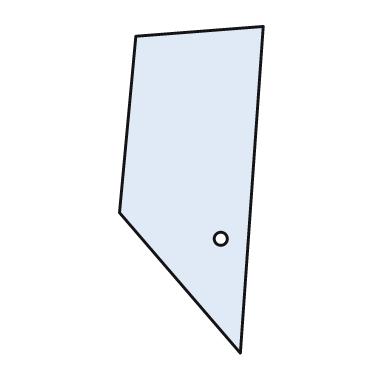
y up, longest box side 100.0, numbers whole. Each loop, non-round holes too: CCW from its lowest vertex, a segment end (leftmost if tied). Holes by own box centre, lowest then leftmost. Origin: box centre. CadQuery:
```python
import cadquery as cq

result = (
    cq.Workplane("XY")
    .moveTo(15.0, -50.0)
    .lineTo(22.0, 50.0)
    .lineTo(-17.0, 47.0)
    .lineTo(-22.0, -7.0)
    .close()
    .moveTo(9.0, -15.0)
    .circle(2.0)
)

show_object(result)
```